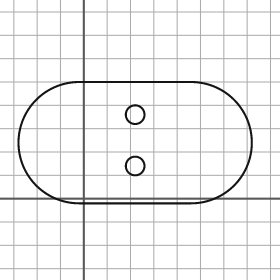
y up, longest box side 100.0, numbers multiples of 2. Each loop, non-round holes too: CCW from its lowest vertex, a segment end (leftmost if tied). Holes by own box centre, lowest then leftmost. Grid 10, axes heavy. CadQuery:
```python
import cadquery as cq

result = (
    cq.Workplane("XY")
    .moveTo(-2.0, -2.0)
    .lineTo(46.0, -2.0)
    .threePointArc((72.0, 24.0), (46.0, 50.0))
    .lineTo(-2.0, 50.0)
    .threePointArc((-28.0, 24.0), (-2.0, -2.0))
    .close()
    .moveTo(22.0, 14.0)
    .circle(4.0)
    .moveTo(22.0, 36.0)
    .circle(4.0)
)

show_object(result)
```